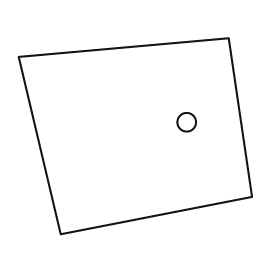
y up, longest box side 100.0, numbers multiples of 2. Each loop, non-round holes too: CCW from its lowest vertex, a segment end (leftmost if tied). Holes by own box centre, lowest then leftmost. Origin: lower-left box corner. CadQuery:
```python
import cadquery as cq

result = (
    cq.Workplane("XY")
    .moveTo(18.0, 0.0)
    .lineTo(100.0, 16.0)
    .lineTo(90.0, 84.0)
    .lineTo(0.0, 76.0)
    .close()
    .moveTo(72.0, 48.0)
    .circle(4.0)
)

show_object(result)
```